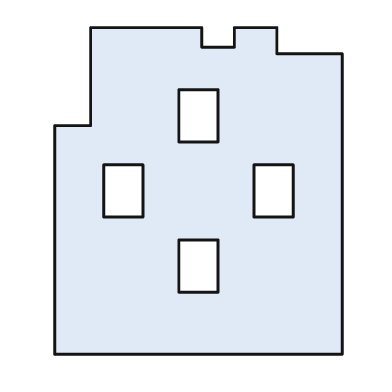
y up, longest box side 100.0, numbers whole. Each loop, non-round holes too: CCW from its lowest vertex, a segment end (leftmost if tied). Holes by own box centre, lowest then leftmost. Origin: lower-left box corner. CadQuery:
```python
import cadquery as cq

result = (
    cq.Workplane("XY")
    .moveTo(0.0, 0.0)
    .lineTo(88.0, 0.0)
    .lineTo(88.0, 92.0)
    .lineTo(68.0, 92.0)
    .lineTo(68.0, 100.0)
    .lineTo(55.0, 100.0)
    .lineTo(55.0, 94.0)
    .lineTo(45.0, 94.0)
    .lineTo(45.0, 100.0)
    .lineTo(11.0, 100.0)
    .lineTo(11.0, 70.0)
    .lineTo(0.0, 70.0)
    .close()
    .moveTo(38.0, 19.0)
    .lineTo(50.0, 19.0)
    .lineTo(50.0, 35.0)
    .lineTo(38.0, 35.0)
    .close()
    .moveTo(15.0, 42.0)
    .lineTo(27.0, 42.0)
    .lineTo(27.0, 58.0)
    .lineTo(15.0, 58.0)
    .close()
    .moveTo(61.0, 42.0)
    .lineTo(73.0, 42.0)
    .lineTo(73.0, 58.0)
    .lineTo(61.0, 58.0)
    .close()
    .moveTo(38.0, 65.0)
    .lineTo(50.0, 65.0)
    .lineTo(50.0, 81.0)
    .lineTo(38.0, 81.0)
    .close()
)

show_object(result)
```